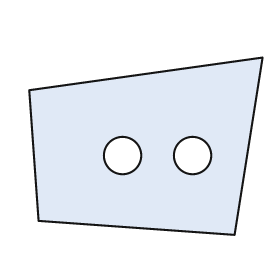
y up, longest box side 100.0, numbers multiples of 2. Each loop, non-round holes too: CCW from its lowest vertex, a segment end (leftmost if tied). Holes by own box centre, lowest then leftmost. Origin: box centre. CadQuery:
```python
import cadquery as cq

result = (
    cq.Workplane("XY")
    .moveTo(38.0, -38.0)
    .lineTo(50.0, 38.0)
    .lineTo(-50.0, 24.0)
    .lineTo(-46.0, -32.0)
    .close()
    .moveTo(-10.0, -4.0)
    .circle(8.0)
    .moveTo(20.0, -4.0)
    .circle(8.0)
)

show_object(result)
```